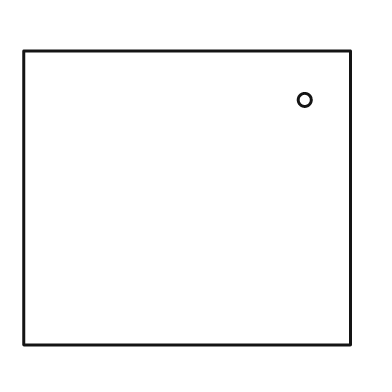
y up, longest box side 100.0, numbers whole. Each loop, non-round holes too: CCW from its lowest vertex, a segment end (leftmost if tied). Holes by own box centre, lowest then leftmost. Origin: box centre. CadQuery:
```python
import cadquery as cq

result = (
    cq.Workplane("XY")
    .moveTo(-50.0, -45.0)
    .lineTo(50.0, -45.0)
    .lineTo(50.0, 45.0)
    .lineTo(-50.0, 45.0)
    .close()
    .moveTo(36.0, 30.0)
    .circle(2.0)
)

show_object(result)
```